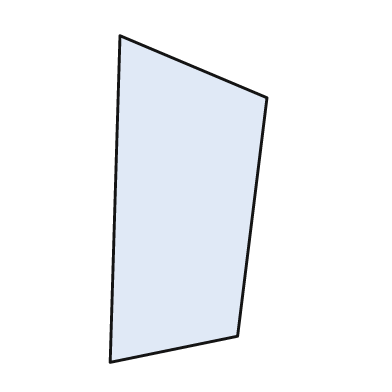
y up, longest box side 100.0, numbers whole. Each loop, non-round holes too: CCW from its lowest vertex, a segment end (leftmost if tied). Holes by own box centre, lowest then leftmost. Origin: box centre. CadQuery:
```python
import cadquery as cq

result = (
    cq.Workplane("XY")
    .moveTo(-24.0, -50.0)
    .lineTo(15.0, -42.0)
    .lineTo(24.0, 31.0)
    .lineTo(-21.0, 50.0)
    .close()
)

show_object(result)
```